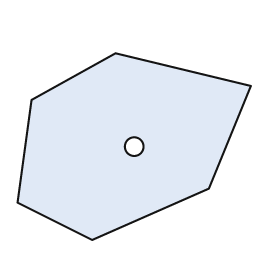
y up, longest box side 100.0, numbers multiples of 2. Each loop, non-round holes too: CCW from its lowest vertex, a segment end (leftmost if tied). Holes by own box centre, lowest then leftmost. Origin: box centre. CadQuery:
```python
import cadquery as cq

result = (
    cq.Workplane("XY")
    .moveTo(-18.0, -40.0)
    .lineTo(32.0, -18.0)
    .lineTo(50.0, 26.0)
    .lineTo(-8.0, 40.0)
    .lineTo(-44.0, 20.0)
    .lineTo(-50.0, -24.0)
    .close()
    .moveTo(0.0, 0.0)
    .circle(4.0)
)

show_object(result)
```